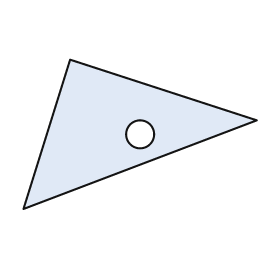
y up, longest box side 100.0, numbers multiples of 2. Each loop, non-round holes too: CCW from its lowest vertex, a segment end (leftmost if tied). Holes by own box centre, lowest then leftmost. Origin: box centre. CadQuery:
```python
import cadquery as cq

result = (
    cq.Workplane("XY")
    .moveTo(-50.0, -32.0)
    .lineTo(50.0, 6.0)
    .lineTo(-30.0, 32.0)
    .close()
    .moveTo(0.0, 0.0)
    .circle(6.0)
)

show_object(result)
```